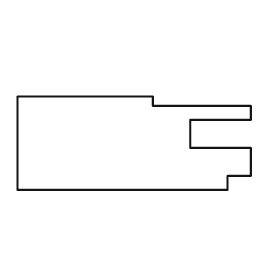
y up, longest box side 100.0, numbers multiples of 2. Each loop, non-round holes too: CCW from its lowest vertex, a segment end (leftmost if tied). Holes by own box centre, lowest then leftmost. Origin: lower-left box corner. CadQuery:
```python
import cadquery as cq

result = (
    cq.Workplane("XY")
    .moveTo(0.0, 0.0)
    .lineTo(90.0, 0.0)
    .lineTo(90.0, 6.0)
    .lineTo(100.0, 6.0)
    .lineTo(100.0, 18.0)
    .lineTo(74.0, 18.0)
    .lineTo(74.0, 30.0)
    .lineTo(100.0, 30.0)
    .lineTo(100.0, 36.0)
    .lineTo(58.0, 36.0)
    .lineTo(58.0, 40.0)
    .lineTo(0.0, 40.0)
    .close()
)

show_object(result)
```